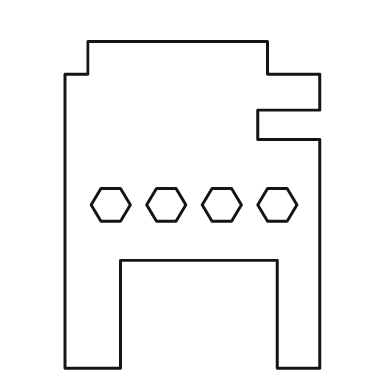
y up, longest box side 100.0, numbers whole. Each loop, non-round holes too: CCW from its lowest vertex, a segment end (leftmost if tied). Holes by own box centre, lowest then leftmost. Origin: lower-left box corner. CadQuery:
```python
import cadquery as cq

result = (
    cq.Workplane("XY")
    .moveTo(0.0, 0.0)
    .lineTo(17.0, 0.0)
    .lineTo(17.0, 33.0)
    .lineTo(65.0, 33.0)
    .lineTo(65.0, 0.0)
    .lineTo(78.0, 0.0)
    .lineTo(78.0, 70.0)
    .lineTo(59.0, 70.0)
    .lineTo(59.0, 79.0)
    .lineTo(78.0, 79.0)
    .lineTo(78.0, 90.0)
    .lineTo(62.0, 90.0)
    .lineTo(62.0, 100.0)
    .lineTo(7.0, 100.0)
    .lineTo(7.0, 90.0)
    .lineTo(0.0, 90.0)
    .close()
    .moveTo(11.0, 45.0)
    .lineTo(17.0, 45.0)
    .lineTo(20.0, 50.0)
    .lineTo(17.0, 55.0)
    .lineTo(11.0, 55.0)
    .lineTo(8.0, 50.0)
    .close()
    .moveTo(28.0, 45.0)
    .lineTo(34.0, 45.0)
    .lineTo(37.0, 50.0)
    .lineTo(34.0, 55.0)
    .lineTo(28.0, 55.0)
    .lineTo(25.0, 50.0)
    .close()
    .moveTo(45.0, 45.0)
    .lineTo(51.0, 45.0)
    .lineTo(54.0, 50.0)
    .lineTo(51.0, 55.0)
    .lineTo(45.0, 55.0)
    .lineTo(42.0, 50.0)
    .close()
    .moveTo(62.0, 45.0)
    .lineTo(68.0, 45.0)
    .lineTo(71.0, 50.0)
    .lineTo(68.0, 55.0)
    .lineTo(62.0, 55.0)
    .lineTo(59.0, 50.0)
    .close()
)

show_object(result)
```